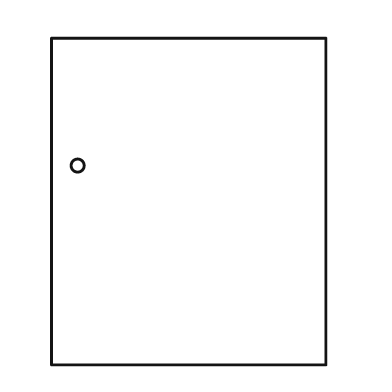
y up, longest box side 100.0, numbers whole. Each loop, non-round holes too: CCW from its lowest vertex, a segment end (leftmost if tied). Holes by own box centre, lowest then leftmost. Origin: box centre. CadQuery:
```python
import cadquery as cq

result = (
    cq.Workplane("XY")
    .moveTo(-42.0, -50.0)
    .lineTo(42.0, -50.0)
    .lineTo(42.0, 50.0)
    .lineTo(-42.0, 50.0)
    .close()
    .moveTo(-34.0, 11.0)
    .circle(2.0)
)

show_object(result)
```